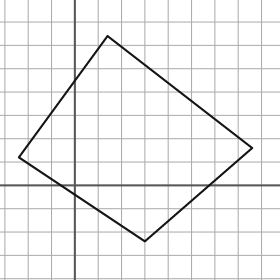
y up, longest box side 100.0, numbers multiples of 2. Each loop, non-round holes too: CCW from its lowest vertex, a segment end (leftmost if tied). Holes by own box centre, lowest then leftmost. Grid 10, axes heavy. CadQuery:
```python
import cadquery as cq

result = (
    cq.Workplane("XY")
    .moveTo(30.0, -24.0)
    .lineTo(76.0, 16.0)
    .lineTo(14.0, 64.0)
    .lineTo(-24.0, 12.0)
    .close()
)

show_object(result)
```